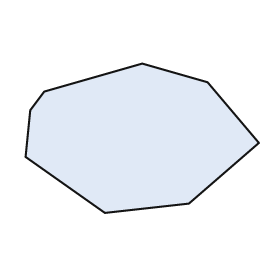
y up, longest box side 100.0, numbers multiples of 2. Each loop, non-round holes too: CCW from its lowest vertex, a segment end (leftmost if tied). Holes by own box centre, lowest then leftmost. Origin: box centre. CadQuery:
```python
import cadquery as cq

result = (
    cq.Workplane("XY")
    .moveTo(-16.0, -32.0)
    .lineTo(20.0, -28.0)
    .lineTo(50.0, -2.0)
    .lineTo(28.0, 24.0)
    .lineTo(0.0, 32.0)
    .lineTo(-42.0, 20.0)
    .lineTo(-48.0, 12.0)
    .lineTo(-50.0, -8.0)
    .close()
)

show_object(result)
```